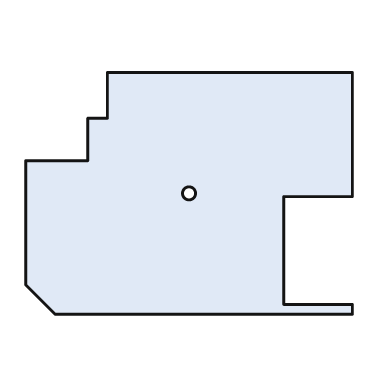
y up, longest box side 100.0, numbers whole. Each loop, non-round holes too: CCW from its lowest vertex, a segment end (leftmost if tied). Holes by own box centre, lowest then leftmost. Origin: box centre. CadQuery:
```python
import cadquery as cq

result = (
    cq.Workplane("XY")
    .moveTo(-41.0, -37.0)
    .lineTo(50.0, -37.0)
    .lineTo(50.0, -34.0)
    .lineTo(29.0, -34.0)
    .lineTo(29.0, -1.0)
    .lineTo(50.0, -1.0)
    .lineTo(50.0, 37.0)
    .lineTo(-25.0, 37.0)
    .lineTo(-25.0, 23.0)
    .lineTo(-31.0, 23.0)
    .lineTo(-31.0, 10.0)
    .lineTo(-50.0, 10.0)
    .lineTo(-50.0, -28.0)
    .close()
    .moveTo(0.0, 0.0)
    .circle(2.0)
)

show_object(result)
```